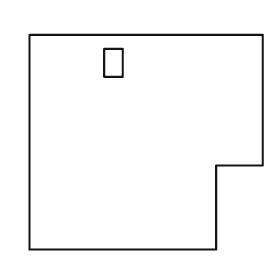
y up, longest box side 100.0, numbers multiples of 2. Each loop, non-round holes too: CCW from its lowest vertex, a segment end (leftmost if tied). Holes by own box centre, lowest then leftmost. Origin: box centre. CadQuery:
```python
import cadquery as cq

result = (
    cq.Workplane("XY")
    .moveTo(-50.0, -46.0)
    .lineTo(30.0, -46.0)
    .lineTo(30.0, -10.0)
    .lineTo(50.0, -10.0)
    .lineTo(50.0, 46.0)
    .lineTo(-50.0, 46.0)
    .close()
    .moveTo(-18.0, 28.0)
    .lineTo(-10.0, 28.0)
    .lineTo(-10.0, 40.0)
    .lineTo(-18.0, 40.0)
    .close()
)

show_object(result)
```